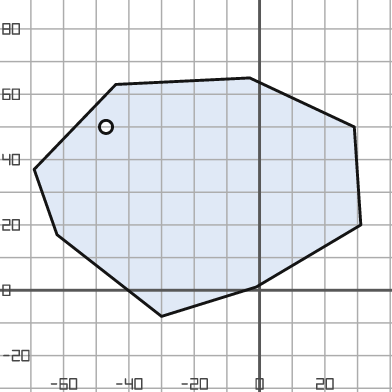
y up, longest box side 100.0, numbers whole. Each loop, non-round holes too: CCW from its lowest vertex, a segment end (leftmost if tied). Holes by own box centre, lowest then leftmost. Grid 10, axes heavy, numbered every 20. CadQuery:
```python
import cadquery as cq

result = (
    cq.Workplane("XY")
    .moveTo(-30.0, -8.0)
    .lineTo(-1.0, 1.0)
    .lineTo(31.0, 20.0)
    .lineTo(29.0, 50.0)
    .lineTo(-3.0, 65.0)
    .lineTo(-44.0, 63.0)
    .lineTo(-69.0, 37.0)
    .lineTo(-62.0, 17.0)
    .close()
    .moveTo(-47.0, 50.0)
    .circle(2.0)
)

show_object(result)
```